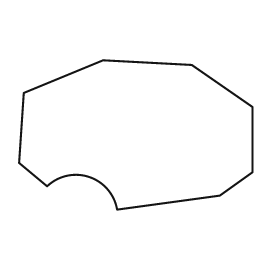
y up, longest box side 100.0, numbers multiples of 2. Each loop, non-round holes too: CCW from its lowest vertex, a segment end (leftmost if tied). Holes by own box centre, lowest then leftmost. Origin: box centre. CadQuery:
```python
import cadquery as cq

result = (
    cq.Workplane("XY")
    .moveTo(-8.0, -32.0)
    .lineTo(36.0, -26.0)
    .lineTo(50.0, -16.0)
    .lineTo(50.0, 12.0)
    .lineTo(24.0, 30.0)
    .lineTo(-14.0, 32.0)
    .lineTo(-48.0, 18.0)
    .lineTo(-50.0, -12.0)
    .lineTo(-38.0, -22.0)
    .threePointArc((-20.0, -18.0), (-8.0, -32.0))
    .close()
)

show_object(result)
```